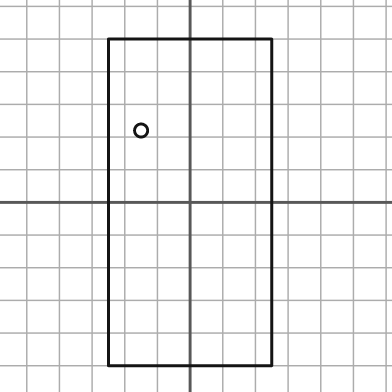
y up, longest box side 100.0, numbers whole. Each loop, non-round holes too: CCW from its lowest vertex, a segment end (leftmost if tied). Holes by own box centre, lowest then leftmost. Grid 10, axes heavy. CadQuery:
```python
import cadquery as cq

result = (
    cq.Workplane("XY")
    .moveTo(-25.0, -50.0)
    .lineTo(25.0, -50.0)
    .lineTo(25.0, 50.0)
    .lineTo(-25.0, 50.0)
    .close()
    .moveTo(-15.0, 22.0)
    .circle(2.0)
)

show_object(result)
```